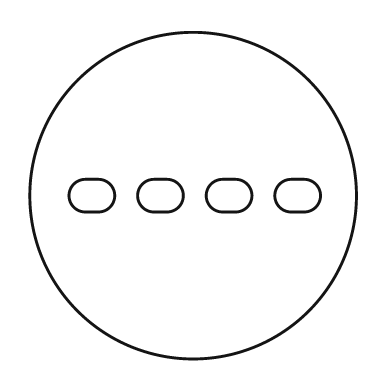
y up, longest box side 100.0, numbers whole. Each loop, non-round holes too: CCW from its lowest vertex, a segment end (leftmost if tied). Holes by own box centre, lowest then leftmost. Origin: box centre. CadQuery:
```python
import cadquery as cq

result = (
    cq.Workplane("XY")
    .moveTo(0.0, 0.0)
    .circle(50.0)
    .moveTo(-33.0, -5.0)
    .lineTo(-29.0, -5.0)
    .threePointArc((-24.0, 0.0), (-29.0, 5.0))
    .lineTo(-33.0, 5.0)
    .threePointArc((-38.0, 0.0), (-33.0, -5.0))
    .close()
    .moveTo(-12.0, -5.0)
    .lineTo(-8.0, -5.0)
    .threePointArc((-3.0, 0.0), (-8.0, 5.0))
    .lineTo(-12.0, 5.0)
    .threePointArc((-17.0, 0.0), (-12.0, -5.0))
    .close()
    .moveTo(9.0, -5.0)
    .lineTo(13.0, -5.0)
    .threePointArc((18.0, 0.0), (13.0, 5.0))
    .lineTo(9.0, 5.0)
    .threePointArc((4.0, 0.0), (9.0, -5.0))
    .close()
    .moveTo(30.0, -5.0)
    .lineTo(34.0, -5.0)
    .threePointArc((39.0, 0.0), (34.0, 5.0))
    .lineTo(30.0, 5.0)
    .threePointArc((25.0, 0.0), (30.0, -5.0))
    .close()
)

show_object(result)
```